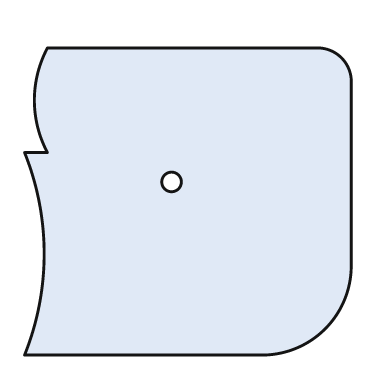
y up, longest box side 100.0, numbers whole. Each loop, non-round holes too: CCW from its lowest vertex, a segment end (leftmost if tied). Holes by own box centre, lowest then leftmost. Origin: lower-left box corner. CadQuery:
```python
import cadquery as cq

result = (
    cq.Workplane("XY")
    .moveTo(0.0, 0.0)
    .lineTo(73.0, 0.0)
    .threePointArc((92.0, 8.0), (100.0, 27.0))
    .lineTo(100.0, 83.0)
    .threePointArc((97.0, 91.0), (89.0, 94.0))
    .lineTo(7.0, 94.0)
    .threePointArc((3.0, 78.0), (7.0, 62.0))
    .lineTo(0.0, 62.0)
    .threePointArc((6.0, 31.0), (0.0, 0.0))
    .close()
    .moveTo(45.0, 53.0)
    .circle(3.0)
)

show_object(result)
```